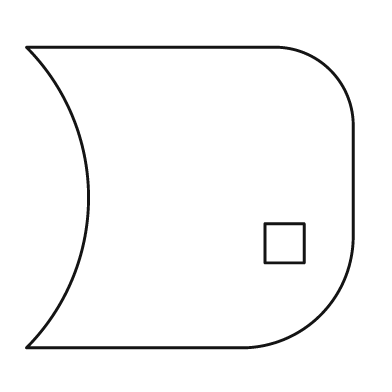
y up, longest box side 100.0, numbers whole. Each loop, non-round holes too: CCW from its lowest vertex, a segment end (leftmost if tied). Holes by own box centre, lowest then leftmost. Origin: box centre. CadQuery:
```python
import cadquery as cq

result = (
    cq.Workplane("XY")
    .moveTo(-50.0, -46.0)
    .lineTo(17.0, -46.0)
    .threePointArc((40.0, -36.0), (50.0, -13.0))
    .lineTo(50.0, 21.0)
    .threePointArc((43.0, 39.0), (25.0, 46.0))
    .lineTo(-50.0, 46.0)
    .threePointArc((-31.0, 0.0), (-50.0, -46.0))
    .close()
    .moveTo(23.0, -20.0)
    .lineTo(35.0, -20.0)
    .lineTo(35.0, -8.0)
    .lineTo(23.0, -8.0)
    .close()
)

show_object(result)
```